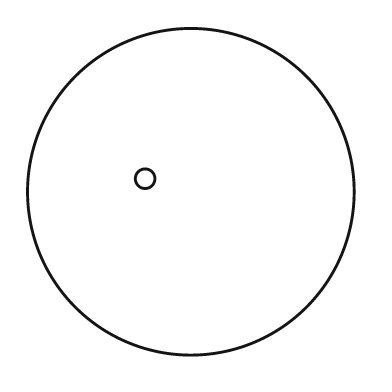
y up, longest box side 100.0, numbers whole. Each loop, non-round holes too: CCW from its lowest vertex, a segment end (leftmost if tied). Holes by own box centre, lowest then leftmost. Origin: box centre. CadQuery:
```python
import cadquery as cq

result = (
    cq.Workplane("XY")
    .moveTo(0.0, 0.0)
    .circle(50.0)
    .moveTo(-14.0, 4.0)
    .circle(3.0)
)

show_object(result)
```